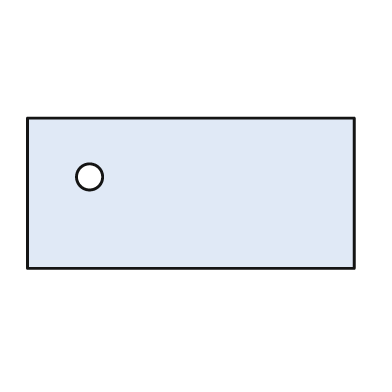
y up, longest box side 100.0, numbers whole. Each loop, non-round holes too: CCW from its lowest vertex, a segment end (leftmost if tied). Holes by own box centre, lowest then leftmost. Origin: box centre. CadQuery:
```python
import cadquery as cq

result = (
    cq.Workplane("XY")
    .moveTo(-50.0, -23.0)
    .lineTo(50.0, -23.0)
    .lineTo(50.0, 23.0)
    .lineTo(-50.0, 23.0)
    .close()
    .moveTo(-31.0, 5.0)
    .circle(4.0)
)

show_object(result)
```